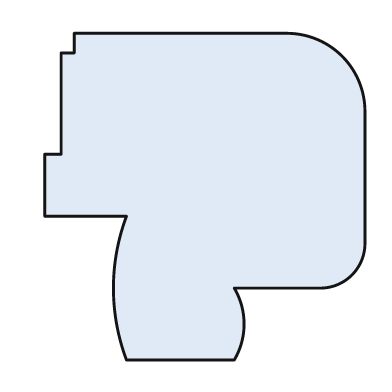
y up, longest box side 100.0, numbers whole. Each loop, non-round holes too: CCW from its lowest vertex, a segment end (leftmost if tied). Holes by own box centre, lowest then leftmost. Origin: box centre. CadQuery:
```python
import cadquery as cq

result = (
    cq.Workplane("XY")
    .moveTo(-24.0, -50.0)
    .lineTo(9.0, -50.0)
    .threePointArc((12.0, -39.0), (9.0, -28.0))
    .lineTo(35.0, -28.0)
    .threePointArc((45.0, -24.0), (49.0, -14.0))
    .lineTo(49.0, 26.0)
    .threePointArc((42.0, 43.0), (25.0, 50.0))
    .lineTo(-40.0, 50.0)
    .lineTo(-40.0, 44.0)
    .lineTo(-44.0, 44.0)
    .lineTo(-44.0, 13.0)
    .lineTo(-49.0, 13.0)
    .lineTo(-49.0, -6.0)
    .lineTo(-24.0, -6.0)
    .threePointArc((-28.0, -28.0), (-24.0, -50.0))
    .close()
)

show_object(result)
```